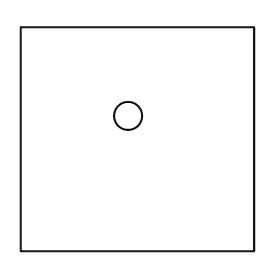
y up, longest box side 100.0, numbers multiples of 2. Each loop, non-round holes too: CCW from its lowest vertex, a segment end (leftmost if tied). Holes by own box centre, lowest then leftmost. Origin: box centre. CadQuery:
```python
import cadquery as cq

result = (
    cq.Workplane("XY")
    .moveTo(-50.0, -48.0)
    .lineTo(50.0, -48.0)
    .lineTo(50.0, 48.0)
    .lineTo(-50.0, 48.0)
    .close()
    .moveTo(-4.0, 10.0)
    .circle(6.0)
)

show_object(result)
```